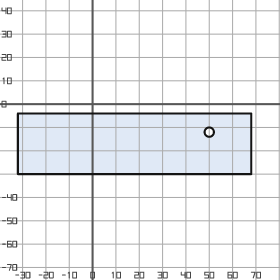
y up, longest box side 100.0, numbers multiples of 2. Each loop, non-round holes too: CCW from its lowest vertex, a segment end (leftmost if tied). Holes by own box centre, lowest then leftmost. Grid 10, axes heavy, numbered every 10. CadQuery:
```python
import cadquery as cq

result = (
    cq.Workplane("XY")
    .moveTo(-32.0, -30.0)
    .lineTo(68.0, -30.0)
    .lineTo(68.0, -4.0)
    .lineTo(-32.0, -4.0)
    .close()
    .moveTo(50.0, -12.0)
    .circle(2.0)
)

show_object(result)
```